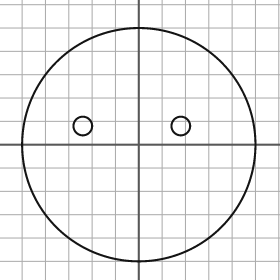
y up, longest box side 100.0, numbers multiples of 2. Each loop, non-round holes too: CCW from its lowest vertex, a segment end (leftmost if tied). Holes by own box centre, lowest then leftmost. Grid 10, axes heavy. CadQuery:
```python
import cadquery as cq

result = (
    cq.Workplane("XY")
    .moveTo(0.0, 0.0)
    .circle(50.0)
    .moveTo(-24.0, 8.0)
    .circle(4.0)
    .moveTo(18.0, 8.0)
    .circle(4.0)
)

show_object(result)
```